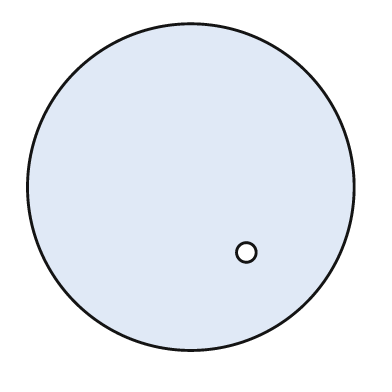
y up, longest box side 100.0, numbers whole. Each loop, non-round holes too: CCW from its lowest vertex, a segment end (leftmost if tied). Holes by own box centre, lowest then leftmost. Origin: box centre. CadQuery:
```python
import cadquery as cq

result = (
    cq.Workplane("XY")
    .moveTo(0.0, 0.0)
    .circle(50.0)
    .moveTo(17.0, -20.0)
    .circle(3.0)
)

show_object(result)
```